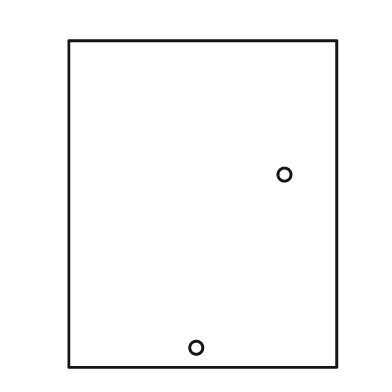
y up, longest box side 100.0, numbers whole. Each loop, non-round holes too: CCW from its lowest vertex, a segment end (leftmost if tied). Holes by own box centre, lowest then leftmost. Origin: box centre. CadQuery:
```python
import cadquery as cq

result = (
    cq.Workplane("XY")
    .moveTo(-41.0, -50.0)
    .lineTo(41.0, -50.0)
    .lineTo(41.0, 50.0)
    .lineTo(-41.0, 50.0)
    .close()
    .moveTo(-2.0, -44.0)
    .circle(2.0)
    .moveTo(25.0, 9.0)
    .circle(2.0)
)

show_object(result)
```